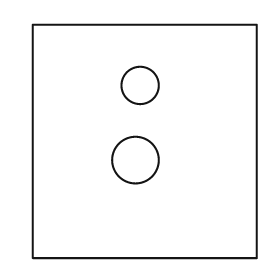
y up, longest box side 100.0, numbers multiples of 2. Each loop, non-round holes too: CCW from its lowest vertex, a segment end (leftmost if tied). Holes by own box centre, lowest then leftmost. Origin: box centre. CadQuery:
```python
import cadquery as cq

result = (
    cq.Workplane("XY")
    .moveTo(-48.0, -50.0)
    .lineTo(48.0, -50.0)
    .lineTo(48.0, 50.0)
    .lineTo(-48.0, 50.0)
    .close()
    .moveTo(-4.0, -8.0)
    .circle(10.0)
    .moveTo(-2.0, 24.0)
    .circle(8.0)
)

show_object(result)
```